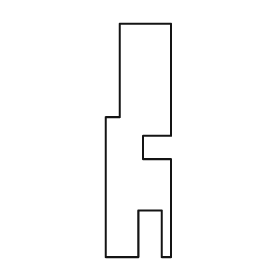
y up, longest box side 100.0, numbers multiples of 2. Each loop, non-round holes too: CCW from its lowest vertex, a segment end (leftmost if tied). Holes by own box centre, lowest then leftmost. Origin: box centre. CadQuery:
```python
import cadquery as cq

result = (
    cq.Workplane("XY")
    .moveTo(-14.0, -50.0)
    .lineTo(0.0, -50.0)
    .lineTo(0.0, -30.0)
    .lineTo(10.0, -30.0)
    .lineTo(10.0, -50.0)
    .lineTo(14.0, -50.0)
    .lineTo(14.0, -8.0)
    .lineTo(2.0, -8.0)
    .lineTo(2.0, 2.0)
    .lineTo(14.0, 2.0)
    .lineTo(14.0, 50.0)
    .lineTo(-8.0, 50.0)
    .lineTo(-8.0, 10.0)
    .lineTo(-14.0, 10.0)
    .close()
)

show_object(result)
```